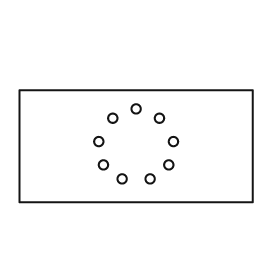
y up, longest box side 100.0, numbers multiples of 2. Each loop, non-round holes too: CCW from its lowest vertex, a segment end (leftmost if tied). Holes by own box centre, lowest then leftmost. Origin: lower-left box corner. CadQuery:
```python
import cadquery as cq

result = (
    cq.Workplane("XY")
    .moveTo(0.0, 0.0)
    .lineTo(100.0, 0.0)
    .lineTo(100.0, 48.0)
    .lineTo(0.0, 48.0)
    .close()
    .moveTo(44.0, 10.0)
    .circle(2.0)
    .moveTo(56.0, 10.0)
    .circle(2.0)
    .moveTo(36.0, 16.0)
    .circle(2.0)
    .moveTo(64.0, 16.0)
    .circle(2.0)
    .moveTo(34.0, 26.0)
    .circle(2.0)
    .moveTo(66.0, 26.0)
    .circle(2.0)
    .moveTo(40.0, 36.0)
    .circle(2.0)
    .moveTo(60.0, 36.0)
    .circle(2.0)
    .moveTo(50.0, 40.0)
    .circle(2.0)
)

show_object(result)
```